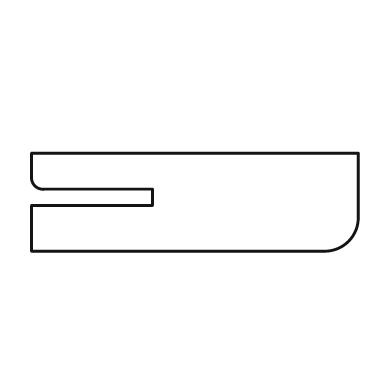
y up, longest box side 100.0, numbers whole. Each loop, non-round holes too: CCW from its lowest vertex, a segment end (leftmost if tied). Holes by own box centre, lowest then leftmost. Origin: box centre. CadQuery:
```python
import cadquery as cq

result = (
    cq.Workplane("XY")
    .moveTo(-50.0, -15.0)
    .lineTo(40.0, -15.0)
    .threePointArc((47.0, -12.0), (50.0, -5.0))
    .lineTo(50.0, 15.0)
    .lineTo(-50.0, 15.0)
    .lineTo(-50.0, 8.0)
    .threePointArc((-49.0, 5.0), (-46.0, 4.0))
    .lineTo(-13.0, 4.0)
    .lineTo(-13.0, -1.0)
    .lineTo(-50.0, -1.0)
    .close()
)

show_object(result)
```